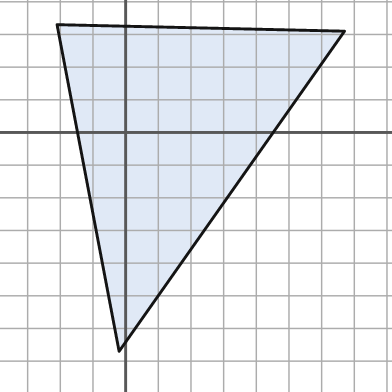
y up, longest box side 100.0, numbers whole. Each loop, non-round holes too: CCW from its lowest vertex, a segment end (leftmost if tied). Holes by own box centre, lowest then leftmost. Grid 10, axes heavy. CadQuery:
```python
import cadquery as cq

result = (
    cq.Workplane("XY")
    .moveTo(-2.0, -67.0)
    .lineTo(67.0, 31.0)
    .lineTo(-21.0, 33.0)
    .close()
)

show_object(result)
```